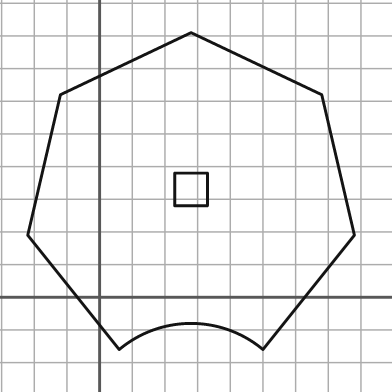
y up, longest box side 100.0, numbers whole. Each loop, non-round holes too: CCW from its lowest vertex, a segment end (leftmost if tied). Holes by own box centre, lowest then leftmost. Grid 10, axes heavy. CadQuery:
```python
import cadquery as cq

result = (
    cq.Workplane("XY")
    .moveTo(6.0, -16.0)
    .threePointArc((28.0, -8.0), (50.0, -16.0))
    .lineTo(78.0, 19.0)
    .lineTo(68.0, 62.0)
    .lineTo(28.0, 81.0)
    .lineTo(-12.0, 62.0)
    .lineTo(-22.0, 19.0)
    .close()
    .moveTo(23.0, 28.0)
    .lineTo(33.0, 28.0)
    .lineTo(33.0, 38.0)
    .lineTo(23.0, 38.0)
    .close()
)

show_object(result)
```